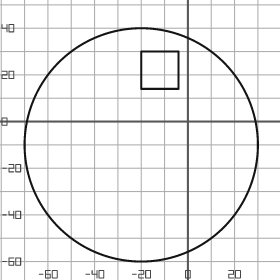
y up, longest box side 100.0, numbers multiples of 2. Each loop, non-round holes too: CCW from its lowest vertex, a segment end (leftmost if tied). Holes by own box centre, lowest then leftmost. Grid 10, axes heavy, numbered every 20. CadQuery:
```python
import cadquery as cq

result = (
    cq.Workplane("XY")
    .moveTo(-20.0, -10.0)
    .circle(50.0)
    .moveTo(-20.0, 14.0)
    .lineTo(-4.0, 14.0)
    .lineTo(-4.0, 30.0)
    .lineTo(-20.0, 30.0)
    .close()
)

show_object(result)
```